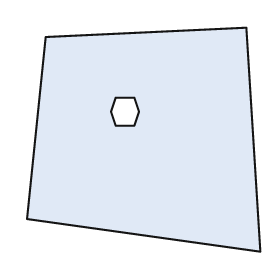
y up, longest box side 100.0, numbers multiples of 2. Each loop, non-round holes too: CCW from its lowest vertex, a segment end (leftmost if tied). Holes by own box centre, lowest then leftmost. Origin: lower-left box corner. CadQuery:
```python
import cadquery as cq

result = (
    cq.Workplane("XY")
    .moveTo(100.0, 0.0)
    .lineTo(94.0, 96.0)
    .lineTo(8.0, 92.0)
    .lineTo(0.0, 14.0)
    .close()
    .moveTo(38.0, 54.0)
    .lineTo(46.0, 54.0)
    .lineTo(48.0, 60.0)
    .lineTo(46.0, 66.0)
    .lineTo(38.0, 66.0)
    .lineTo(36.0, 60.0)
    .close()
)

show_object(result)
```